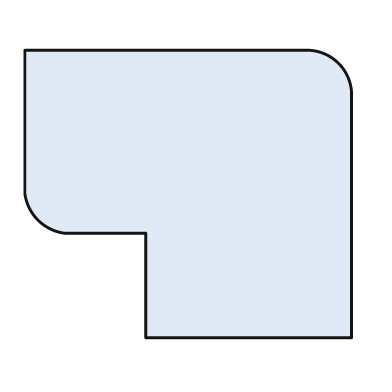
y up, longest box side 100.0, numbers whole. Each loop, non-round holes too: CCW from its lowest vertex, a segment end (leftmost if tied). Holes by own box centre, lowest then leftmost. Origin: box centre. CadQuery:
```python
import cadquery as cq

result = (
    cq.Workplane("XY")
    .moveTo(-13.0, -44.0)
    .lineTo(50.0, -44.0)
    .lineTo(50.0, 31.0)
    .threePointArc((46.0, 40.0), (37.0, 44.0))
    .lineTo(-50.0, 44.0)
    .lineTo(-50.0, 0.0)
    .threePointArc((-46.0, -8.0), (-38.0, -12.0))
    .lineTo(-13.0, -12.0)
    .close()
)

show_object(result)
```